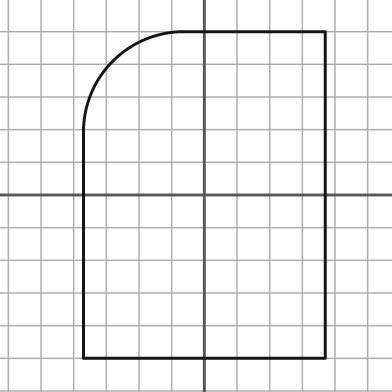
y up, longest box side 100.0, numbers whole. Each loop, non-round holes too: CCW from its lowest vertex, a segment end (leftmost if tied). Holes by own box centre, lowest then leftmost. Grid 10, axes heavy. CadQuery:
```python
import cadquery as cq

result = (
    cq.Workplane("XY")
    .moveTo(-37.0, -50.0)
    .lineTo(37.0, -50.0)
    .lineTo(37.0, 50.0)
    .lineTo(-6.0, 50.0)
    .threePointArc((-28.0, 41.0), (-37.0, 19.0))
    .close()
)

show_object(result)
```